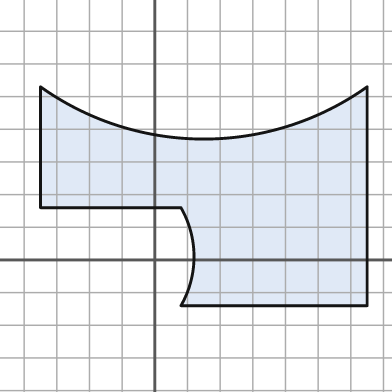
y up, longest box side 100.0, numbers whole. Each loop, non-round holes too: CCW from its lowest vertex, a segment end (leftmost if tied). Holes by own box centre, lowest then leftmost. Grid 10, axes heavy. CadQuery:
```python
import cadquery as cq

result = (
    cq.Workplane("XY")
    .moveTo(8.0, -14.0)
    .lineTo(65.0, -14.0)
    .lineTo(65.0, 53.0)
    .threePointArc((15.0, 37.0), (-35.0, 53.0))
    .lineTo(-35.0, 16.0)
    .lineTo(8.0, 16.0)
    .threePointArc((12.0, 1.0), (8.0, -14.0))
    .close()
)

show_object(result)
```